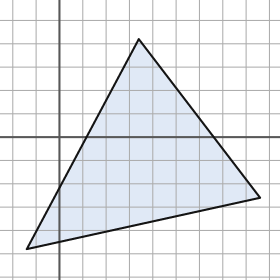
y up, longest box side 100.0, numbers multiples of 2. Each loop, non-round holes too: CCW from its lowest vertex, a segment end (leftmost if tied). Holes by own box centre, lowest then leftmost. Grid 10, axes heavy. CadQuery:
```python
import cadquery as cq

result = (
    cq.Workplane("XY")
    .moveTo(-14.0, -48.0)
    .lineTo(86.0, -26.0)
    .lineTo(34.0, 42.0)
    .close()
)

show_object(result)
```